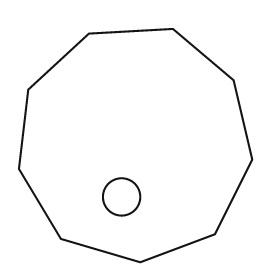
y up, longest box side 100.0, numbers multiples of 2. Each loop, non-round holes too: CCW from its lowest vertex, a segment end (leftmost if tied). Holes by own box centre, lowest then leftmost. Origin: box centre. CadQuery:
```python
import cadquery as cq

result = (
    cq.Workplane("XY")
    .moveTo(2.0, -50.0)
    .lineTo(34.0, -38.0)
    .lineTo(50.0, -6.0)
    .lineTo(42.0, 28.0)
    .lineTo(16.0, 50.0)
    .lineTo(-20.0, 48.0)
    .lineTo(-46.0, 24.0)
    .lineTo(-50.0, -10.0)
    .lineTo(-32.0, -40.0)
    .close()
    .moveTo(-6.0, -22.0)
    .circle(8.0)
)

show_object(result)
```